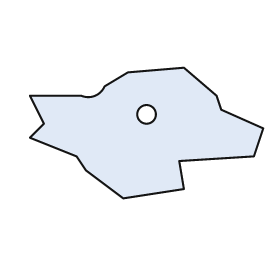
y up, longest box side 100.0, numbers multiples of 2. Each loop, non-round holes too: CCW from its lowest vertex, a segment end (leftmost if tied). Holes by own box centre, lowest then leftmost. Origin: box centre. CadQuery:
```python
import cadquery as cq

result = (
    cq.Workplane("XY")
    .moveTo(-10.0, -28.0)
    .lineTo(16.0, -24.0)
    .lineTo(14.0, -12.0)
    .lineTo(46.0, -10.0)
    .lineTo(50.0, 2.0)
    .lineTo(32.0, 10.0)
    .lineTo(30.0, 16.0)
    .lineTo(16.0, 28.0)
    .lineTo(-8.0, 26.0)
    .lineTo(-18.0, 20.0)
    .threePointArc((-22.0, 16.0), (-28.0, 16.0))
    .lineTo(-50.0, 16.0)
    .lineTo(-44.0, 4.0)
    .lineTo(-50.0, -2.0)
    .lineTo(-30.0, -10.0)
    .lineTo(-26.0, -16.0)
    .close()
    .moveTo(0.0, 8.0)
    .circle(4.0)
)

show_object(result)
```